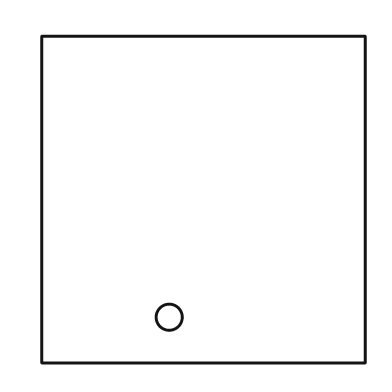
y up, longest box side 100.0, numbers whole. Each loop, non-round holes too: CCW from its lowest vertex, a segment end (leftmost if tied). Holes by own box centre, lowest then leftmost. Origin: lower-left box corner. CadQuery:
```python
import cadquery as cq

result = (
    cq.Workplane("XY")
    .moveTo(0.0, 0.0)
    .lineTo(99.0, 0.0)
    .lineTo(99.0, 100.0)
    .lineTo(0.0, 100.0)
    .close()
    .moveTo(39.0, 14.0)
    .circle(4.0)
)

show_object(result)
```